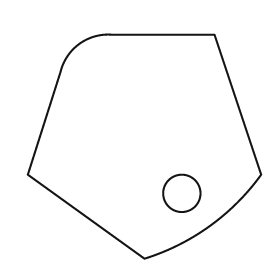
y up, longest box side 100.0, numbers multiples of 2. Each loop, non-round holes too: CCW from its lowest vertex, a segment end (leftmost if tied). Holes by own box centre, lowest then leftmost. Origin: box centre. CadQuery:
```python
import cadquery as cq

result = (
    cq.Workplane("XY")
    .moveTo(0.0, -48.0)
    .threePointArc((28.0, -34.0), (50.0, -12.0))
    .lineTo(30.0, 48.0)
    .lineTo(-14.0, 48.0)
    .threePointArc((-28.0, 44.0), (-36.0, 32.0))
    .lineTo(-50.0, -12.0)
    .close()
    .moveTo(16.0, -20.0)
    .circle(8.0)
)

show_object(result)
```